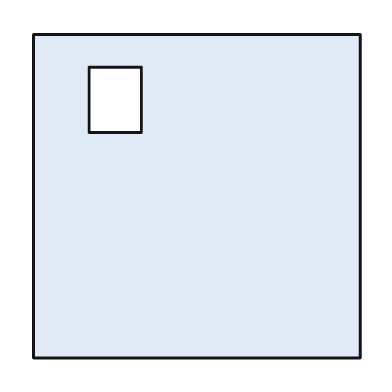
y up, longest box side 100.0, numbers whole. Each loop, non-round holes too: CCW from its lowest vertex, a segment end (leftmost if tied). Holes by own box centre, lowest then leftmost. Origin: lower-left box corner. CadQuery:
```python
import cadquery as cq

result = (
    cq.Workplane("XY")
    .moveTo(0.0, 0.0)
    .lineTo(100.0, 0.0)
    .lineTo(100.0, 99.0)
    .lineTo(0.0, 99.0)
    .close()
    .moveTo(17.0, 69.0)
    .lineTo(33.0, 69.0)
    .lineTo(33.0, 89.0)
    .lineTo(17.0, 89.0)
    .close()
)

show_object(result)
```